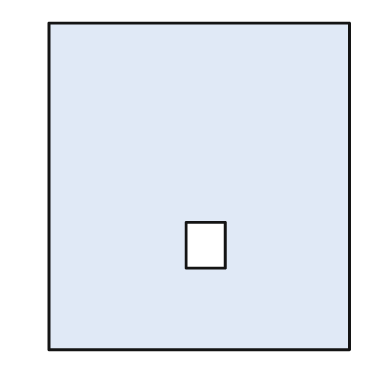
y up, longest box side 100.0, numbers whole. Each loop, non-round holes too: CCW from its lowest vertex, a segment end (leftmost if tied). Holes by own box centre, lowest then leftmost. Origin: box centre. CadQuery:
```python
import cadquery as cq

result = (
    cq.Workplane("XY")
    .moveTo(-46.0, -50.0)
    .lineTo(46.0, -50.0)
    .lineTo(46.0, 50.0)
    .lineTo(-46.0, 50.0)
    .close()
    .moveTo(-4.0, -25.0)
    .lineTo(8.0, -25.0)
    .lineTo(8.0, -11.0)
    .lineTo(-4.0, -11.0)
    .close()
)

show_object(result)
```